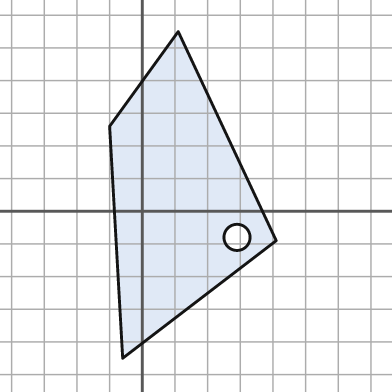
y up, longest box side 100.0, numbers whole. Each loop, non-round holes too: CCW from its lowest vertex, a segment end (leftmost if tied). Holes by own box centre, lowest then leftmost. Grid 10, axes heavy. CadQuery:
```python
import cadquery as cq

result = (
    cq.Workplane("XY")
    .moveTo(-6.0, -45.0)
    .lineTo(41.0, -9.0)
    .lineTo(11.0, 55.0)
    .lineTo(-10.0, 26.0)
    .close()
    .moveTo(29.0, -8.0)
    .circle(4.0)
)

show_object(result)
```